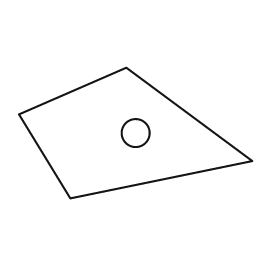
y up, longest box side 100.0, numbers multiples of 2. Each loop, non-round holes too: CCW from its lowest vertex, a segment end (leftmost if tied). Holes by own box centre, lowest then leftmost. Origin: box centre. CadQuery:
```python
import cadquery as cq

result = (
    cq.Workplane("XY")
    .moveTo(-28.0, -28.0)
    .lineTo(50.0, -12.0)
    .lineTo(-4.0, 28.0)
    .lineTo(-50.0, 8.0)
    .close()
    .moveTo(0.0, 0.0)
    .circle(6.0)
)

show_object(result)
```